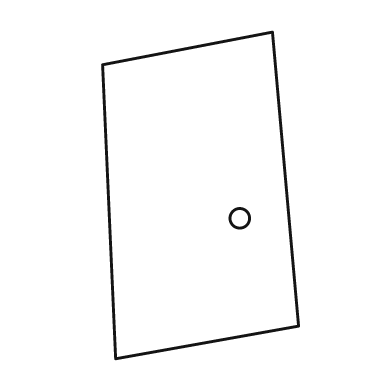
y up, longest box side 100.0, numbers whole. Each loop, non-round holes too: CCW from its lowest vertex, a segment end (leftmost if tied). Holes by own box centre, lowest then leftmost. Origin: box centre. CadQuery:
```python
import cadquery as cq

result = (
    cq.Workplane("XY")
    .moveTo(-26.0, -50.0)
    .lineTo(30.0, -40.0)
    .lineTo(22.0, 50.0)
    .lineTo(-30.0, 40.0)
    .close()
    .moveTo(12.0, -7.0)
    .circle(3.0)
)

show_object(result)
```